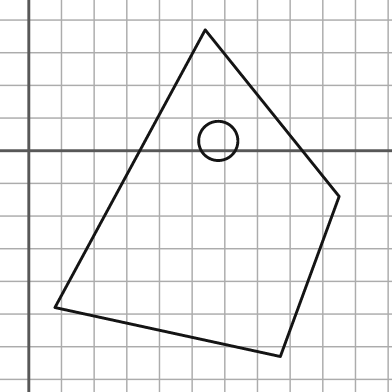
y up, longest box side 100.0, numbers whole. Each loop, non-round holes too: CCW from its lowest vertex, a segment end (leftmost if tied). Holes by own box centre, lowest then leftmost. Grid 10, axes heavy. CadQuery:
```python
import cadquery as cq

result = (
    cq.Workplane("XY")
    .moveTo(77.0, -63.0)
    .lineTo(95.0, -14.0)
    .lineTo(54.0, 37.0)
    .lineTo(8.0, -48.0)
    .close()
    .moveTo(58.0, 3.0)
    .circle(6.0)
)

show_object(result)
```